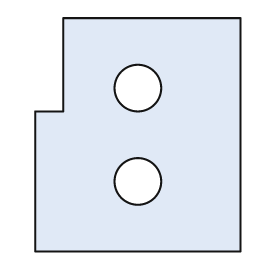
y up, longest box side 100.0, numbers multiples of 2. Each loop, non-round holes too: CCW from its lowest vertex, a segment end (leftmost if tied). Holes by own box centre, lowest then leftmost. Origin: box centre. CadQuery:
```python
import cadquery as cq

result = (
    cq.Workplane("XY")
    .moveTo(-44.0, -50.0)
    .lineTo(44.0, -50.0)
    .lineTo(44.0, 50.0)
    .lineTo(-32.0, 50.0)
    .lineTo(-32.0, 10.0)
    .lineTo(-44.0, 10.0)
    .close()
    .moveTo(0.0, -20.0)
    .circle(10.0)
    .moveTo(0.0, 20.0)
    .circle(10.0)
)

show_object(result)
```